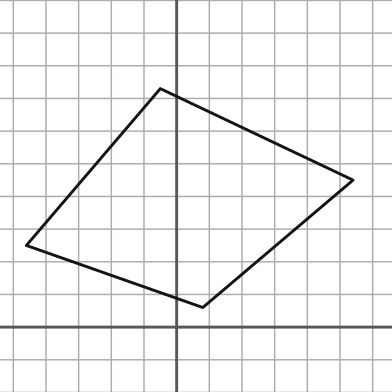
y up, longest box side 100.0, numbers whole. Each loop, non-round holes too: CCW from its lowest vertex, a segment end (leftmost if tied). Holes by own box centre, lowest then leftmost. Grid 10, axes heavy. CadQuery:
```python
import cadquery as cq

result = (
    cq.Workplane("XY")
    .moveTo(8.0, 6.0)
    .lineTo(54.0, 45.0)
    .lineTo(-5.0, 73.0)
    .lineTo(-46.0, 25.0)
    .close()
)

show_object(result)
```